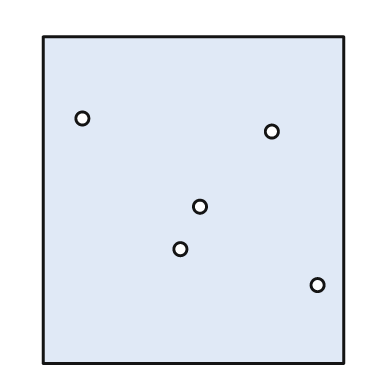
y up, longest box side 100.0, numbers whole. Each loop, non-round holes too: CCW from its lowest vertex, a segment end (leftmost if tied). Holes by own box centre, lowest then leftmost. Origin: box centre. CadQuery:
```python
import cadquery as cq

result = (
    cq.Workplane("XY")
    .moveTo(-46.0, -50.0)
    .lineTo(46.0, -50.0)
    .lineTo(46.0, 50.0)
    .lineTo(-46.0, 50.0)
    .close()
    .moveTo(38.0, -26.0)
    .circle(2.0)
    .moveTo(-4.0, -15.0)
    .circle(2.0)
    .moveTo(2.0, -2.0)
    .circle(2.0)
    .moveTo(24.0, 21.0)
    .circle(2.0)
    .moveTo(-34.0, 25.0)
    .circle(2.0)
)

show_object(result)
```